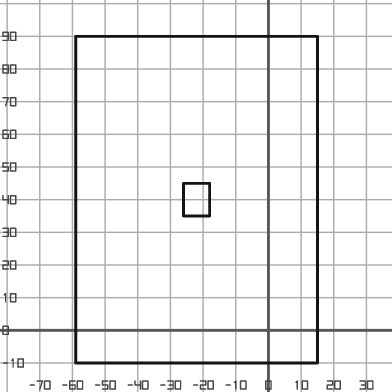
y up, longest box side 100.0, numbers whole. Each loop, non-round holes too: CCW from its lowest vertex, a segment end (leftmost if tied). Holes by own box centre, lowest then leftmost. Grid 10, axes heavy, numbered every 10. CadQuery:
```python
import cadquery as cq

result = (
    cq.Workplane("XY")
    .moveTo(-59.0, -10.0)
    .lineTo(15.0, -10.0)
    .lineTo(15.0, 90.0)
    .lineTo(-59.0, 90.0)
    .close()
    .moveTo(-26.0, 35.0)
    .lineTo(-18.0, 35.0)
    .lineTo(-18.0, 45.0)
    .lineTo(-26.0, 45.0)
    .close()
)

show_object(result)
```